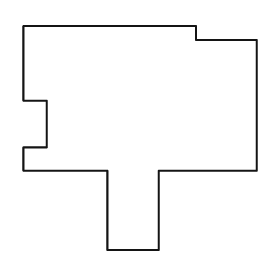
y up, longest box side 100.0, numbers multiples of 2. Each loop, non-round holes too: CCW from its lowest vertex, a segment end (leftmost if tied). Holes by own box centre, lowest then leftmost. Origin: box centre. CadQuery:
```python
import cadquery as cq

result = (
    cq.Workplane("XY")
    .moveTo(-14.0, -48.0)
    .lineTo(8.0, -48.0)
    .lineTo(8.0, -14.0)
    .lineTo(50.0, -14.0)
    .lineTo(50.0, 42.0)
    .lineTo(24.0, 42.0)
    .lineTo(24.0, 48.0)
    .lineTo(-50.0, 48.0)
    .lineTo(-50.0, 16.0)
    .lineTo(-40.0, 16.0)
    .lineTo(-40.0, -4.0)
    .lineTo(-50.0, -4.0)
    .lineTo(-50.0, -14.0)
    .lineTo(-14.0, -14.0)
    .close()
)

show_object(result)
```